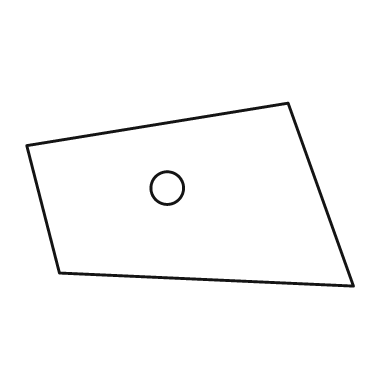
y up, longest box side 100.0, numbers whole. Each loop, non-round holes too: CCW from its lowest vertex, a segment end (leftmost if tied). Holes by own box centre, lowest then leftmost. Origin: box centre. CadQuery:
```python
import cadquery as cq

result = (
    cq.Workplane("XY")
    .moveTo(50.0, -28.0)
    .lineTo(30.0, 28.0)
    .lineTo(-50.0, 15.0)
    .lineTo(-40.0, -24.0)
    .close()
    .moveTo(-7.0, 2.0)
    .circle(5.0)
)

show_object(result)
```